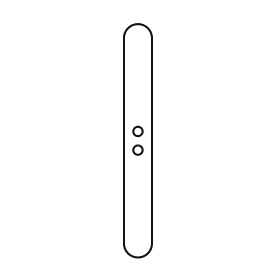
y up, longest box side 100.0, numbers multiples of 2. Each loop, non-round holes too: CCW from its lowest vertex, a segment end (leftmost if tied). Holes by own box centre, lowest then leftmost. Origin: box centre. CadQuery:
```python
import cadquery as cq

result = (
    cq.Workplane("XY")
    .moveTo(-6.0, -44.0)
    .threePointArc((0.0, -50.0), (6.0, -44.0))
    .lineTo(6.0, 44.0)
    .threePointArc((0.0, 50.0), (-6.0, 44.0))
    .close()
    .moveTo(0.0, -4.0)
    .circle(2.0)
    .moveTo(0.0, 4.0)
    .circle(2.0)
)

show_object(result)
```